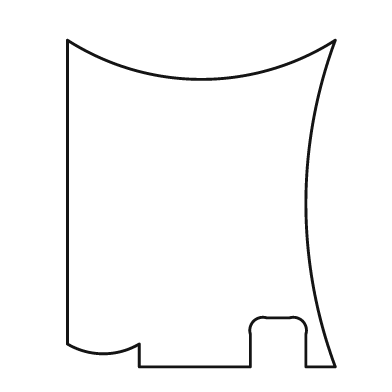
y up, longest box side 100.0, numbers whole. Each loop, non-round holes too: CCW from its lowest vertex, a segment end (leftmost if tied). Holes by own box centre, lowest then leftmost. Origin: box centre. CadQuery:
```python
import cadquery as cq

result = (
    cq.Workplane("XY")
    .moveTo(-19.0, -50.0)
    .lineTo(15.0, -50.0)
    .lineTo(15.0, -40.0)
    .threePointArc((16.0, -36.0), (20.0, -35.0))
    .lineTo(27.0, -35.0)
    .threePointArc((31.0, -36.0), (32.0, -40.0))
    .lineTo(32.0, -50.0)
    .lineTo(41.0, -50.0)
    .threePointArc((32.0, 0.0), (41.0, 50.0))
    .threePointArc((0.0, 38.0), (-41.0, 50.0))
    .lineTo(-41.0, -43.0)
    .threePointArc((-30.0, -46.0), (-19.0, -43.0))
    .close()
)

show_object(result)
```